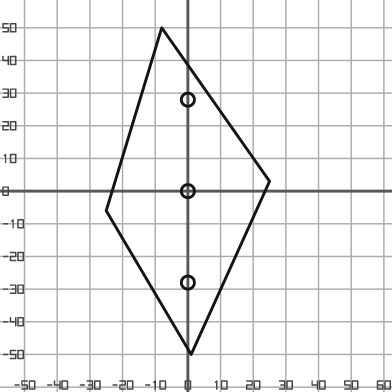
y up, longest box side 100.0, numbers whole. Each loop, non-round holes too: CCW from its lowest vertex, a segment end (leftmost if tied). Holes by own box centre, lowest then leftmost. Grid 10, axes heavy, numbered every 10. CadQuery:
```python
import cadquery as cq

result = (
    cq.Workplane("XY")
    .moveTo(1.0, -50.0)
    .lineTo(25.0, 3.0)
    .lineTo(-8.0, 50.0)
    .lineTo(-25.0, -6.0)
    .close()
    .moveTo(0.0, -28.0)
    .circle(2.0)
    .moveTo(0.0, 0.0)
    .circle(2.0)
    .moveTo(0.0, 28.0)
    .circle(2.0)
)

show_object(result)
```